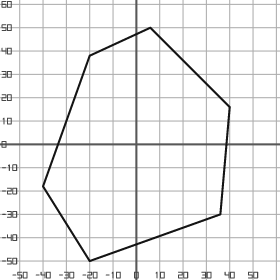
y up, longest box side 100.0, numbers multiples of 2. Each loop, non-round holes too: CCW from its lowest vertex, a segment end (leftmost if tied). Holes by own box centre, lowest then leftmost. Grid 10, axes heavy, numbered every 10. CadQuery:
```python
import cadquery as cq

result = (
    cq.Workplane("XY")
    .moveTo(-20.0, -50.0)
    .lineTo(36.0, -30.0)
    .lineTo(40.0, 16.0)
    .lineTo(6.0, 50.0)
    .lineTo(-20.0, 38.0)
    .lineTo(-40.0, -18.0)
    .close()
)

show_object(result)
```